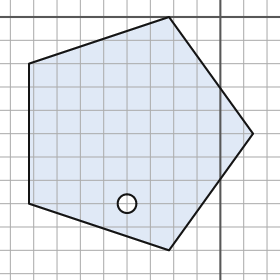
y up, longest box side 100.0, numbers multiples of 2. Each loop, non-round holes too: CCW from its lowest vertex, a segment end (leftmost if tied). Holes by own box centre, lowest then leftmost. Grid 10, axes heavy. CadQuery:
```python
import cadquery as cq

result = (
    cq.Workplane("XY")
    .moveTo(-22.0, -100.0)
    .lineTo(14.0, -50.0)
    .lineTo(-22.0, 0.0)
    .lineTo(-82.0, -20.0)
    .lineTo(-82.0, -80.0)
    .close()
    .moveTo(-40.0, -80.0)
    .circle(4.0)
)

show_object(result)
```